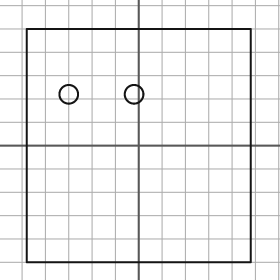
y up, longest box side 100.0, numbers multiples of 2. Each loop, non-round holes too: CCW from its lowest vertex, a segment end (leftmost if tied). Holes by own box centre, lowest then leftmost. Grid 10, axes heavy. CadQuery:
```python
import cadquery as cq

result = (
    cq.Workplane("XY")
    .moveTo(-48.0, -50.0)
    .lineTo(48.0, -50.0)
    .lineTo(48.0, 50.0)
    .lineTo(-48.0, 50.0)
    .close()
    .moveTo(-30.0, 22.0)
    .circle(4.0)
    .moveTo(-2.0, 22.0)
    .circle(4.0)
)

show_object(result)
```